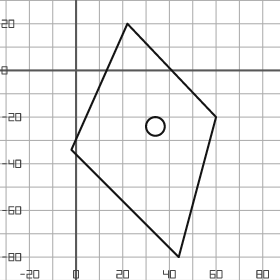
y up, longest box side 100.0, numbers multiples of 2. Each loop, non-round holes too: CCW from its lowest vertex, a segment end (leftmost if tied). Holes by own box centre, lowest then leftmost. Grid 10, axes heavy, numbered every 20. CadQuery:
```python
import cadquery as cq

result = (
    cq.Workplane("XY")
    .moveTo(44.0, -80.0)
    .lineTo(60.0, -20.0)
    .lineTo(22.0, 20.0)
    .lineTo(-2.0, -34.0)
    .close()
    .moveTo(34.0, -24.0)
    .circle(4.0)
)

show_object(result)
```